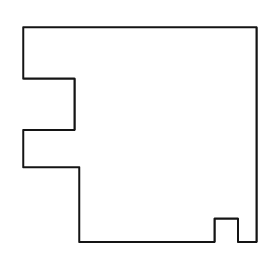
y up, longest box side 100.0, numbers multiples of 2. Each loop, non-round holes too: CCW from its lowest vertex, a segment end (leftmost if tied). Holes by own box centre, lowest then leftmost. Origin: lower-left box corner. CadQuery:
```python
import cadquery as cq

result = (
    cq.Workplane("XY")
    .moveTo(24.0, 0.0)
    .lineTo(82.0, 0.0)
    .lineTo(82.0, 10.0)
    .lineTo(92.0, 10.0)
    .lineTo(92.0, 0.0)
    .lineTo(100.0, 0.0)
    .lineTo(100.0, 92.0)
    .lineTo(0.0, 92.0)
    .lineTo(0.0, 70.0)
    .lineTo(22.0, 70.0)
    .lineTo(22.0, 48.0)
    .lineTo(0.0, 48.0)
    .lineTo(0.0, 32.0)
    .lineTo(24.0, 32.0)
    .close()
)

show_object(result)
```